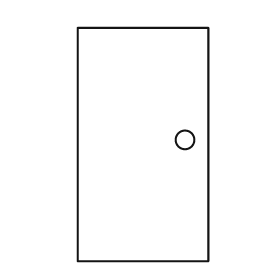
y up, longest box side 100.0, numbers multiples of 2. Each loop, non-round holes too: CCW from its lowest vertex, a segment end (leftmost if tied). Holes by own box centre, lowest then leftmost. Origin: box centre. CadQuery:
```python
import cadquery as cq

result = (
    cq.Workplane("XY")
    .moveTo(-28.0, -50.0)
    .lineTo(28.0, -50.0)
    .lineTo(28.0, 50.0)
    .lineTo(-28.0, 50.0)
    .close()
    .moveTo(18.0, 2.0)
    .circle(4.0)
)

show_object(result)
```